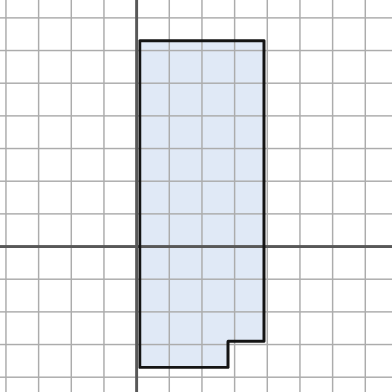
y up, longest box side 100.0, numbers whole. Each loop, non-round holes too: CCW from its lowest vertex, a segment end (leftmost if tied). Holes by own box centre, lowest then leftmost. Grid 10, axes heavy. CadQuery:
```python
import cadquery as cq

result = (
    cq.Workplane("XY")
    .moveTo(1.0, -37.0)
    .lineTo(28.0, -37.0)
    .lineTo(28.0, -29.0)
    .lineTo(39.0, -29.0)
    .lineTo(39.0, 63.0)
    .lineTo(1.0, 63.0)
    .close()
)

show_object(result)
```